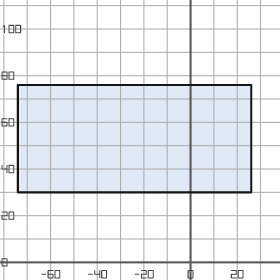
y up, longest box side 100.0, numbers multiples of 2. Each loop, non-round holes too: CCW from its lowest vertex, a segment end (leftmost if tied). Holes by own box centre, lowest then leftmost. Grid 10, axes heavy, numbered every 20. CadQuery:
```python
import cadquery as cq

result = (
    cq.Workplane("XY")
    .moveTo(-74.0, 30.0)
    .lineTo(26.0, 30.0)
    .lineTo(26.0, 76.0)
    .lineTo(-74.0, 76.0)
    .close()
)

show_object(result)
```